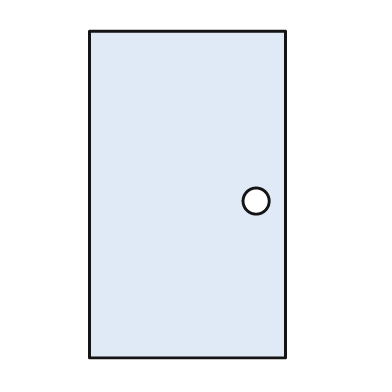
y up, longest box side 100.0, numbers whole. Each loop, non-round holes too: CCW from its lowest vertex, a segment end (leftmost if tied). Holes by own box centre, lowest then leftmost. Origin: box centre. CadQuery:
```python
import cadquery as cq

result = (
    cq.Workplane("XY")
    .moveTo(-30.0, -50.0)
    .lineTo(30.0, -50.0)
    .lineTo(30.0, 50.0)
    .lineTo(-30.0, 50.0)
    .close()
    .moveTo(21.0, -2.0)
    .circle(4.0)
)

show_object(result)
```